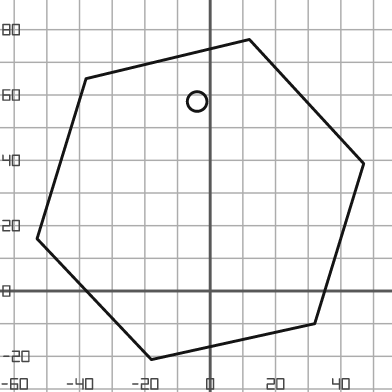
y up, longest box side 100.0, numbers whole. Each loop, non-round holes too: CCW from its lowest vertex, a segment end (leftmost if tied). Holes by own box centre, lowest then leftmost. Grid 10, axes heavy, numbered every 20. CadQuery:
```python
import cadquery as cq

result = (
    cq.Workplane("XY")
    .moveTo(-18.0, -21.0)
    .lineTo(32.0, -10.0)
    .lineTo(47.0, 39.0)
    .lineTo(12.0, 77.0)
    .lineTo(-38.0, 65.0)
    .lineTo(-53.0, 16.0)
    .close()
    .moveTo(-4.0, 58.0)
    .circle(3.0)
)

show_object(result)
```